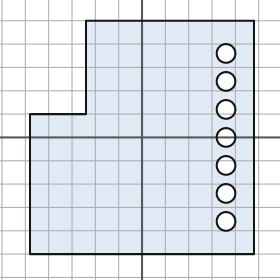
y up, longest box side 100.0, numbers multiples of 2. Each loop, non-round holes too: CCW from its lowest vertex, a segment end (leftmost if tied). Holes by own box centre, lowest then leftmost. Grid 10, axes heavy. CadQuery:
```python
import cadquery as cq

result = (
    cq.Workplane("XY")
    .moveTo(-48.0, -50.0)
    .lineTo(48.0, -50.0)
    .lineTo(48.0, 50.0)
    .lineTo(-24.0, 50.0)
    .lineTo(-24.0, 10.0)
    .lineTo(-48.0, 10.0)
    .close()
    .moveTo(36.0, -36.0)
    .circle(4.0)
    .moveTo(36.0, -24.0)
    .circle(4.0)
    .moveTo(36.0, -12.0)
    .circle(4.0)
    .moveTo(36.0, 0.0)
    .circle(4.0)
    .moveTo(36.0, 12.0)
    .circle(4.0)
    .moveTo(36.0, 24.0)
    .circle(4.0)
    .moveTo(36.0, 36.0)
    .circle(4.0)
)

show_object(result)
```